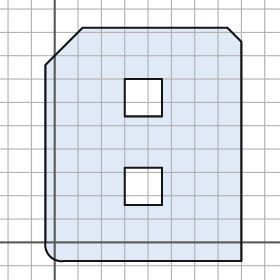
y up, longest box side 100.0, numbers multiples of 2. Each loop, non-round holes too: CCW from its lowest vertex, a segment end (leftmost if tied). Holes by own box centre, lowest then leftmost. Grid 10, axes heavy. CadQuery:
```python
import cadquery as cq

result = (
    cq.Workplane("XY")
    .moveTo(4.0, -8.0)
    .lineTo(80.0, -8.0)
    .lineTo(80.0, 86.0)
    .lineTo(74.0, 92.0)
    .lineTo(12.0, 92.0)
    .lineTo(-4.0, 76.0)
    .lineTo(-4.0, 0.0)
    .threePointArc((-2.0, -6.0), (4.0, -8.0))
    .close()
    .moveTo(30.0, 16.0)
    .lineTo(46.0, 16.0)
    .lineTo(46.0, 32.0)
    .lineTo(30.0, 32.0)
    .close()
    .moveTo(30.0, 54.0)
    .lineTo(46.0, 54.0)
    .lineTo(46.0, 70.0)
    .lineTo(30.0, 70.0)
    .close()
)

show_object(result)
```